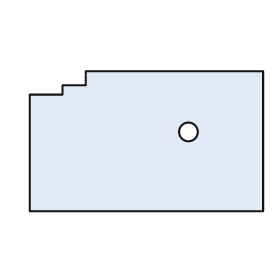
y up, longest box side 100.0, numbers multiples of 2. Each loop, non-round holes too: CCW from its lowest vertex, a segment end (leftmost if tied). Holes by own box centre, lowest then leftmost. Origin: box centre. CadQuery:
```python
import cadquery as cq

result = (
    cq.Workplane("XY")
    .moveTo(-50.0, -30.0)
    .lineTo(50.0, -30.0)
    .lineTo(50.0, 30.0)
    .lineTo(-26.0, 30.0)
    .lineTo(-26.0, 24.0)
    .lineTo(-36.0, 24.0)
    .lineTo(-36.0, 20.0)
    .lineTo(-50.0, 20.0)
    .close()
    .moveTo(18.0, 4.0)
    .circle(4.0)
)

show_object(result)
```